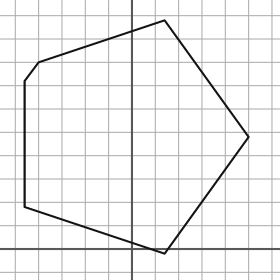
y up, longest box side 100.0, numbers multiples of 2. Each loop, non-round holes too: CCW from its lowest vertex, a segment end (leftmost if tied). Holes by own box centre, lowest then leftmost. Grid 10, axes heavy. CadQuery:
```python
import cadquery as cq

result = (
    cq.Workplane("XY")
    .moveTo(14.0, -2.0)
    .lineTo(50.0, 48.0)
    .lineTo(14.0, 98.0)
    .lineTo(-40.0, 80.0)
    .lineTo(-46.0, 72.0)
    .lineTo(-46.0, 18.0)
    .close()
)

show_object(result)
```